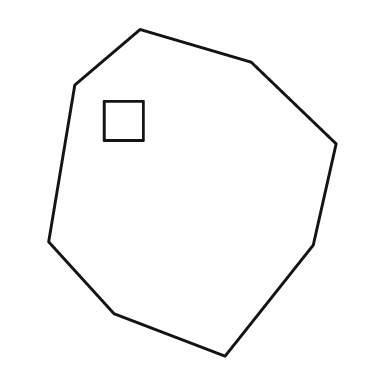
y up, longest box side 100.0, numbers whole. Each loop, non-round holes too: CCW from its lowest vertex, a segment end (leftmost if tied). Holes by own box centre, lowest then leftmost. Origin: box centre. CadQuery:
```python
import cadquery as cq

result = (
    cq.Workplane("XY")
    .moveTo(10.0, -50.0)
    .lineTo(37.0, -16.0)
    .lineTo(44.0, 15.0)
    .lineTo(18.0, 40.0)
    .lineTo(-16.0, 50.0)
    .lineTo(-36.0, 33.0)
    .lineTo(-44.0, -15.0)
    .lineTo(-24.0, -37.0)
    .close()
    .moveTo(-27.0, 16.0)
    .lineTo(-15.0, 16.0)
    .lineTo(-15.0, 28.0)
    .lineTo(-27.0, 28.0)
    .close()
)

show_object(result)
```